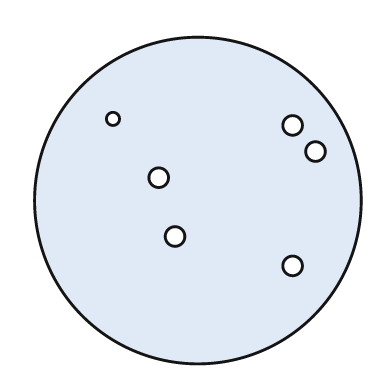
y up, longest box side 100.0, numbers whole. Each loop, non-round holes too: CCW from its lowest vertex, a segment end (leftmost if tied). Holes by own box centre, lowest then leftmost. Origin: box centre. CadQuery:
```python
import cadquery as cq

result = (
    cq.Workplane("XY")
    .moveTo(0.0, 0.0)
    .circle(50.0)
    .moveTo(29.0, -20.0)
    .circle(3.0)
    .moveTo(-7.0, -11.0)
    .circle(3.0)
    .moveTo(-12.0, 7.0)
    .circle(3.0)
    .moveTo(36.0, 15.0)
    .circle(3.0)
    .moveTo(29.0, 23.0)
    .circle(3.0)
    .moveTo(-26.0, 25.0)
    .circle(2.0)
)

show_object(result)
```